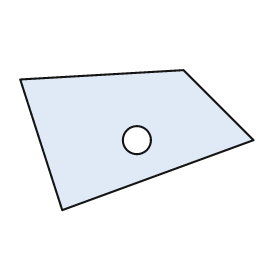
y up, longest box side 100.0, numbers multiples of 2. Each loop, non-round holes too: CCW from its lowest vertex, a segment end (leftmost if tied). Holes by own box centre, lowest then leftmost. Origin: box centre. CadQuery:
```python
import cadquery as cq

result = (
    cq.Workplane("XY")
    .moveTo(-32.0, -30.0)
    .lineTo(50.0, 0.0)
    .lineTo(20.0, 30.0)
    .lineTo(-50.0, 26.0)
    .close()
    .moveTo(0.0, 0.0)
    .circle(6.0)
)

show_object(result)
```